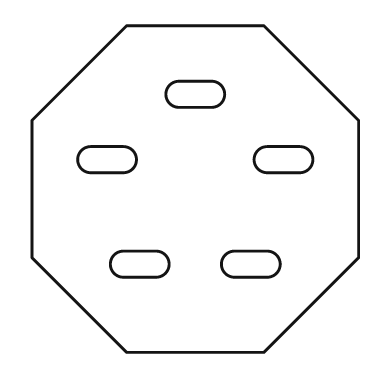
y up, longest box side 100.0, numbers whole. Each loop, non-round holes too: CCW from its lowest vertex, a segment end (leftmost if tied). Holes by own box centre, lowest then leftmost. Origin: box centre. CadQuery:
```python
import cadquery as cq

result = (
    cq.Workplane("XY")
    .moveTo(-21.0, -50.0)
    .lineTo(21.0, -50.0)
    .lineTo(50.0, -21.0)
    .lineTo(50.0, 21.0)
    .lineTo(21.0, 50.0)
    .lineTo(-21.0, 50.0)
    .lineTo(-50.0, 21.0)
    .lineTo(-50.0, -21.0)
    .close()
    .moveTo(-22.0, -27.0)
    .lineTo(-12.0, -27.0)
    .threePointArc((-8.0, -23.0), (-12.0, -19.0))
    .lineTo(-22.0, -19.0)
    .threePointArc((-26.0, -23.0), (-22.0, -27.0))
    .close()
    .moveTo(12.0, -27.0)
    .lineTo(22.0, -27.0)
    .threePointArc((26.0, -23.0), (22.0, -19.0))
    .lineTo(12.0, -19.0)
    .threePointArc((8.0, -23.0), (12.0, -27.0))
    .close()
    .moveTo(-32.0, 5.0)
    .lineTo(-22.0, 5.0)
    .threePointArc((-18.0, 9.0), (-22.0, 13.0))
    .lineTo(-32.0, 13.0)
    .threePointArc((-36.0, 9.0), (-32.0, 5.0))
    .close()
    .moveTo(22.0, 5.0)
    .lineTo(32.0, 5.0)
    .threePointArc((36.0, 9.0), (32.0, 13.0))
    .lineTo(22.0, 13.0)
    .threePointArc((18.0, 9.0), (22.0, 5.0))
    .close()
    .moveTo(-5.0, 25.0)
    .lineTo(5.0, 25.0)
    .threePointArc((9.0, 29.0), (5.0, 33.0))
    .lineTo(-5.0, 33.0)
    .threePointArc((-9.0, 29.0), (-5.0, 25.0))
    .close()
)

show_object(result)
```